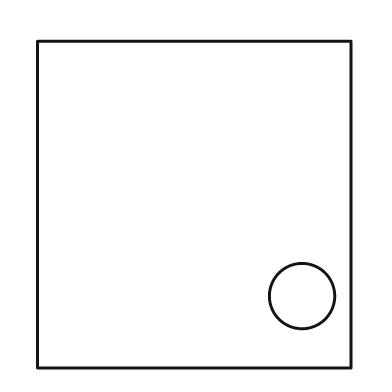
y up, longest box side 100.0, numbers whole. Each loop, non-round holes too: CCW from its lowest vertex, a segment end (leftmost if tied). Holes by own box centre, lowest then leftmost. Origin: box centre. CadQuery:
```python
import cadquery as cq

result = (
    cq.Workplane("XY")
    .moveTo(-48.0, -50.0)
    .lineTo(48.0, -50.0)
    .lineTo(48.0, 50.0)
    .lineTo(-48.0, 50.0)
    .close()
    .moveTo(33.0, -28.0)
    .circle(10.0)
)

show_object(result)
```